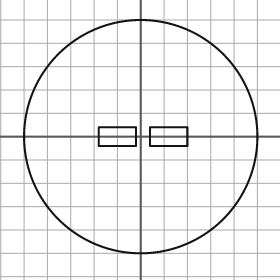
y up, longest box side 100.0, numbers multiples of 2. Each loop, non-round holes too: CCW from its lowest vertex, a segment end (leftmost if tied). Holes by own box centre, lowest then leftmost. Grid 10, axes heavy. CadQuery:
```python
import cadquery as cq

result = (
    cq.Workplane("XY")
    .moveTo(0.0, 0.0)
    .circle(50.0)
    .moveTo(-18.0, -4.0)
    .lineTo(-2.0, -4.0)
    .lineTo(-2.0, 4.0)
    .lineTo(-18.0, 4.0)
    .close()
    .moveTo(4.0, -4.0)
    .lineTo(20.0, -4.0)
    .lineTo(20.0, 4.0)
    .lineTo(4.0, 4.0)
    .close()
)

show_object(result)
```